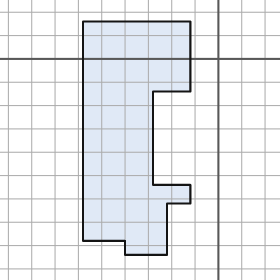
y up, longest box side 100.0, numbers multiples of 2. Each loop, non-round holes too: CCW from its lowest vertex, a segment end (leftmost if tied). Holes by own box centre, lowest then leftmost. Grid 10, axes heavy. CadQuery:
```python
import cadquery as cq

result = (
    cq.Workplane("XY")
    .moveTo(-40.0, -84.0)
    .lineTo(-22.0, -84.0)
    .lineTo(-22.0, -62.0)
    .lineTo(-12.0, -62.0)
    .lineTo(-12.0, -54.0)
    .lineTo(-28.0, -54.0)
    .lineTo(-28.0, -14.0)
    .lineTo(-12.0, -14.0)
    .lineTo(-12.0, 16.0)
    .lineTo(-58.0, 16.0)
    .lineTo(-58.0, -78.0)
    .lineTo(-40.0, -78.0)
    .close()
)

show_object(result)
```